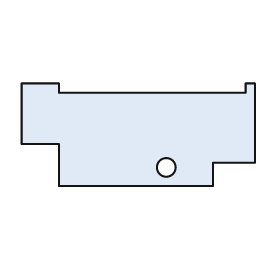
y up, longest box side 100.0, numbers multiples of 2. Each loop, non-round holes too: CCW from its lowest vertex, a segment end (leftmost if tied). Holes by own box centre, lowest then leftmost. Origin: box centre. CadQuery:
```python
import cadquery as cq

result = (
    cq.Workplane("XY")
    .moveTo(-34.0, -22.0)
    .lineTo(32.0, -22.0)
    .lineTo(32.0, -12.0)
    .lineTo(50.0, -12.0)
    .lineTo(50.0, 22.0)
    .lineTo(46.0, 22.0)
    .lineTo(46.0, 18.0)
    .lineTo(-34.0, 18.0)
    .lineTo(-34.0, 22.0)
    .lineTo(-50.0, 22.0)
    .lineTo(-50.0, -4.0)
    .lineTo(-34.0, -4.0)
    .close()
    .moveTo(12.0, -14.0)
    .circle(4.0)
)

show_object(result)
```